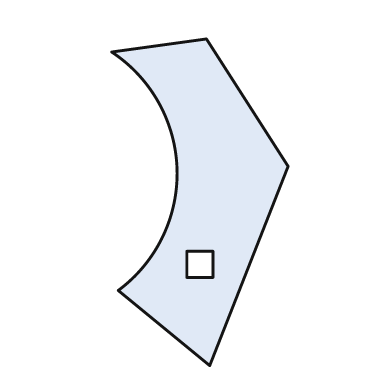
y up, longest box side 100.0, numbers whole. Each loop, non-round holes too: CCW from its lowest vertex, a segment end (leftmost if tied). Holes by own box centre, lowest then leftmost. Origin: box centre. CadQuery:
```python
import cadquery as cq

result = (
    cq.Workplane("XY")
    .moveTo(3.0, -50.0)
    .lineTo(27.0, 11.0)
    .lineTo(2.0, 50.0)
    .lineTo(-27.0, 46.0)
    .threePointArc((-7.0, 10.0), (-25.0, -27.0))
    .close()
    .moveTo(-4.0, -23.0)
    .lineTo(4.0, -23.0)
    .lineTo(4.0, -15.0)
    .lineTo(-4.0, -15.0)
    .close()
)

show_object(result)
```